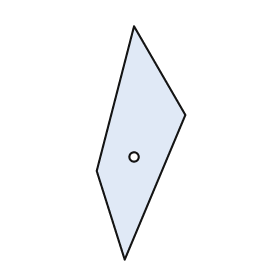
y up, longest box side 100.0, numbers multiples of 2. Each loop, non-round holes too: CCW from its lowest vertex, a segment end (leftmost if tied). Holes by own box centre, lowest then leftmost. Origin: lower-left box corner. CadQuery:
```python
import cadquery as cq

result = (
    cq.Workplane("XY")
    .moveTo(12.0, 0.0)
    .lineTo(38.0, 62.0)
    .lineTo(16.0, 100.0)
    .lineTo(0.0, 38.0)
    .close()
    .moveTo(16.0, 44.0)
    .circle(2.0)
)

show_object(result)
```